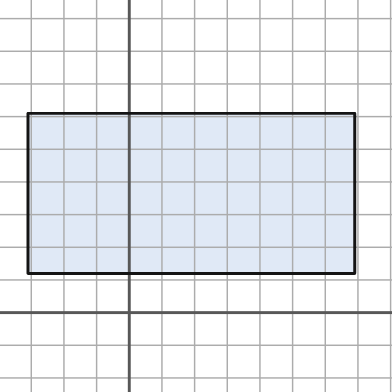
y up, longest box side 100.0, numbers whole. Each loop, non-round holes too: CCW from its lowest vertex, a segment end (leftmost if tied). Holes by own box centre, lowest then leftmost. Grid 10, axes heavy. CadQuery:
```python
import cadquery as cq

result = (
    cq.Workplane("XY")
    .moveTo(-31.0, 12.0)
    .lineTo(69.0, 12.0)
    .lineTo(69.0, 61.0)
    .lineTo(-31.0, 61.0)
    .close()
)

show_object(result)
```